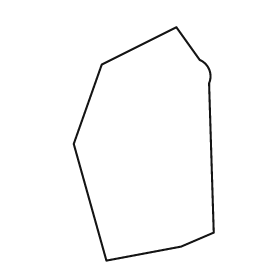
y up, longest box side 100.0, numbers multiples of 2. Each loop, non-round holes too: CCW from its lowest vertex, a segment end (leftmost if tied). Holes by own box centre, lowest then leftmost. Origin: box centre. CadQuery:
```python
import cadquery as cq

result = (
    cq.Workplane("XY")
    .moveTo(-16.0, -50.0)
    .lineTo(16.0, -44.0)
    .lineTo(30.0, -38.0)
    .lineTo(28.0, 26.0)
    .threePointArc((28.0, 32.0), (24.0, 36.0))
    .lineTo(14.0, 50.0)
    .lineTo(-18.0, 34.0)
    .lineTo(-30.0, 0.0)
    .close()
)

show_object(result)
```